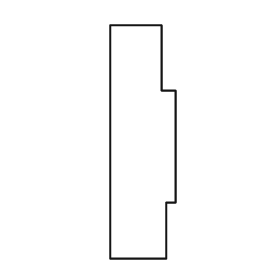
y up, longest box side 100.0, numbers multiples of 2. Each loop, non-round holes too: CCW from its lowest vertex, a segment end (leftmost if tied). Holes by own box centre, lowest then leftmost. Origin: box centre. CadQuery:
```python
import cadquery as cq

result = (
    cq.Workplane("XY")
    .moveTo(-14.0, -50.0)
    .lineTo(10.0, -50.0)
    .lineTo(10.0, -26.0)
    .lineTo(14.0, -26.0)
    .lineTo(14.0, 22.0)
    .lineTo(8.0, 22.0)
    .lineTo(8.0, 50.0)
    .lineTo(-14.0, 50.0)
    .close()
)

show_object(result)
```